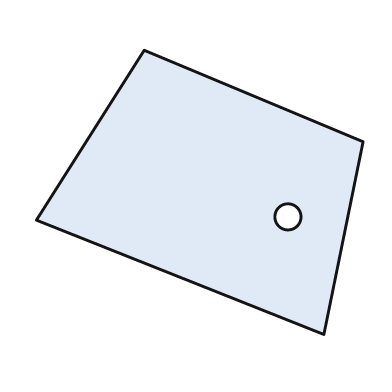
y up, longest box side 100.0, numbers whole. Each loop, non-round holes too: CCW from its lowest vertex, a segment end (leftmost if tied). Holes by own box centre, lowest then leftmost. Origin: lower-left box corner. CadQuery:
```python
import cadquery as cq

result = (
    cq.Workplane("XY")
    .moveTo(88.0, 0.0)
    .lineTo(100.0, 59.0)
    .lineTo(33.0, 87.0)
    .lineTo(0.0, 35.0)
    .close()
    .moveTo(77.0, 36.0)
    .circle(4.0)
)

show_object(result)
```